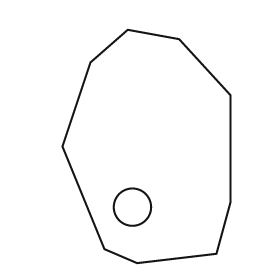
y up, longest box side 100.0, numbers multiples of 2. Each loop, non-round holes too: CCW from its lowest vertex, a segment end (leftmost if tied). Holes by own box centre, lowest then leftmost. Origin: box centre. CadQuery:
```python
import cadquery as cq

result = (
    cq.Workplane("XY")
    .moveTo(-4.0, -50.0)
    .lineTo(30.0, -46.0)
    .lineTo(36.0, -24.0)
    .lineTo(36.0, 22.0)
    .lineTo(14.0, 46.0)
    .lineTo(-8.0, 50.0)
    .lineTo(-24.0, 36.0)
    .lineTo(-36.0, 0.0)
    .lineTo(-18.0, -44.0)
    .close()
    .moveTo(-6.0, -26.0)
    .circle(8.0)
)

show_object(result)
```